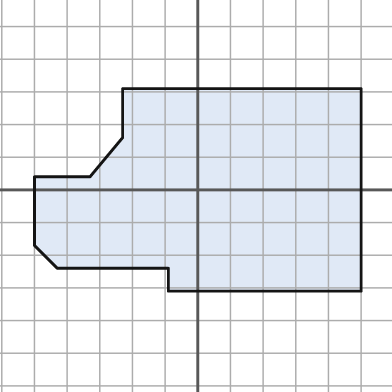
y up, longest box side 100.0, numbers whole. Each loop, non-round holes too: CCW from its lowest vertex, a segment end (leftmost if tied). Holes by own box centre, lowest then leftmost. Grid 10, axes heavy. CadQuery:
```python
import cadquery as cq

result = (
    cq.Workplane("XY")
    .moveTo(-9.0, -31.0)
    .lineTo(50.0, -31.0)
    .lineTo(50.0, 31.0)
    .lineTo(-23.0, 31.0)
    .lineTo(-23.0, 16.0)
    .lineTo(-33.0, 4.0)
    .lineTo(-50.0, 4.0)
    .lineTo(-50.0, -17.0)
    .lineTo(-43.0, -24.0)
    .lineTo(-9.0, -24.0)
    .close()
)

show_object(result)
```